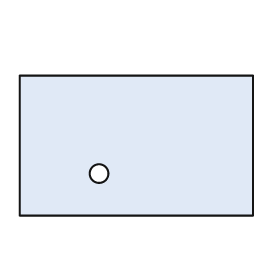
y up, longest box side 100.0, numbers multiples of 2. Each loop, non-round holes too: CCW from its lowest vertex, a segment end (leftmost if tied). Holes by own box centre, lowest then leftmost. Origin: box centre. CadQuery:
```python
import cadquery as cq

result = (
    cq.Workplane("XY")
    .moveTo(-50.0, -30.0)
    .lineTo(50.0, -30.0)
    .lineTo(50.0, 30.0)
    .lineTo(-50.0, 30.0)
    .close()
    .moveTo(-16.0, -12.0)
    .circle(4.0)
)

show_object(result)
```